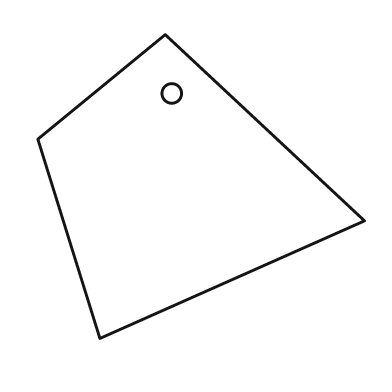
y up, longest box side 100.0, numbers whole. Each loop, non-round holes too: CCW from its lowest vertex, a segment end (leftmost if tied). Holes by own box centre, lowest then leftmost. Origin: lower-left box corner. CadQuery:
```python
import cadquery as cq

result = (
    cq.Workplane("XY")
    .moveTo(19.0, 0.0)
    .lineTo(100.0, 36.0)
    .lineTo(39.0, 93.0)
    .lineTo(0.0, 61.0)
    .close()
    .moveTo(41.0, 75.0)
    .circle(3.0)
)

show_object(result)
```